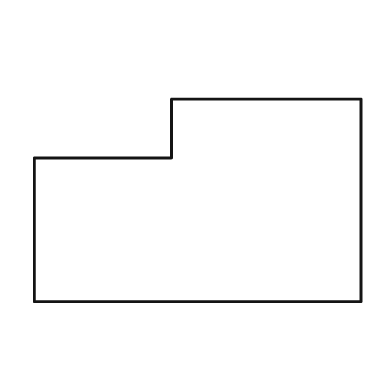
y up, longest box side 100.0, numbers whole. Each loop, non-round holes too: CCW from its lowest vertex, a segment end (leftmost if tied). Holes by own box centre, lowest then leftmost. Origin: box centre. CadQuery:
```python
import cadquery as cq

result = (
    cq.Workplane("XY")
    .moveTo(-50.0, -31.0)
    .lineTo(50.0, -31.0)
    .lineTo(50.0, 31.0)
    .lineTo(-8.0, 31.0)
    .lineTo(-8.0, 13.0)
    .lineTo(-50.0, 13.0)
    .close()
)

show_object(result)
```